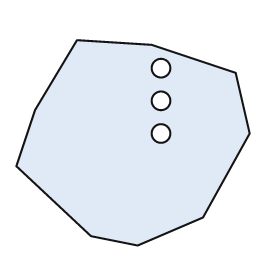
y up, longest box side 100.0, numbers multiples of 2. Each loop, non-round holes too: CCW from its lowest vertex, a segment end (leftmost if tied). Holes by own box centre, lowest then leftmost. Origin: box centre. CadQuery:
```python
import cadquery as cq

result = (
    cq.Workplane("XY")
    .moveTo(2.0, -44.0)
    .lineTo(30.0, -32.0)
    .lineTo(50.0, 4.0)
    .lineTo(44.0, 30.0)
    .lineTo(8.0, 42.0)
    .lineTo(-24.0, 44.0)
    .lineTo(-42.0, 14.0)
    .lineTo(-50.0, -10.0)
    .lineTo(-18.0, -40.0)
    .close()
    .moveTo(12.0, 4.0)
    .circle(4.0)
    .moveTo(12.0, 18.0)
    .circle(4.0)
    .moveTo(12.0, 32.0)
    .circle(4.0)
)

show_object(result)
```